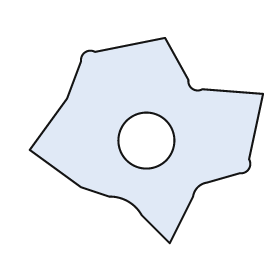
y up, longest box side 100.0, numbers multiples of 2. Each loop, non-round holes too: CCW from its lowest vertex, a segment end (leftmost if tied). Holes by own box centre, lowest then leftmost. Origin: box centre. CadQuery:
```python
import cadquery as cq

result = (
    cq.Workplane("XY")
    .moveTo(10.0, -44.0)
    .lineTo(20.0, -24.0)
    .threePointArc((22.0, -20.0), (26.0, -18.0))
    .lineTo(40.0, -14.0)
    .threePointArc((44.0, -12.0), (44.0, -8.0))
    .lineTo(50.0, 20.0)
    .lineTo(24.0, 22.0)
    .threePointArc((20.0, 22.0), (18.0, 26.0))
    .lineTo(8.0, 44.0)
    .lineTo(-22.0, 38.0)
    .threePointArc((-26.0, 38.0), (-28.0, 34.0))
    .lineTo(-34.0, 18.0)
    .lineTo(-50.0, -4.0)
    .lineTo(-28.0, -20.0)
    .lineTo(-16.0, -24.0)
    .threePointArc((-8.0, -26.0), (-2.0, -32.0))
    .close()
    .moveTo(0.0, 0.0)
    .circle(12.0)
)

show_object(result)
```